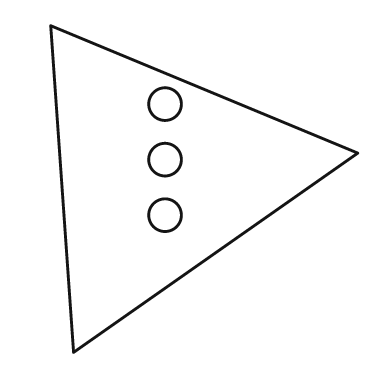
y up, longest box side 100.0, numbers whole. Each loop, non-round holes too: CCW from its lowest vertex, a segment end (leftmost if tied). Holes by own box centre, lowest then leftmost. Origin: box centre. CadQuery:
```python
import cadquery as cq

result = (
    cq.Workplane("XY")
    .moveTo(-40.0, -50.0)
    .lineTo(47.0, 11.0)
    .lineTo(-47.0, 50.0)
    .close()
    .moveTo(-12.0, -8.0)
    .circle(5.0)
    .moveTo(-12.0, 9.0)
    .circle(5.0)
    .moveTo(-12.0, 26.0)
    .circle(5.0)
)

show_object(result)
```